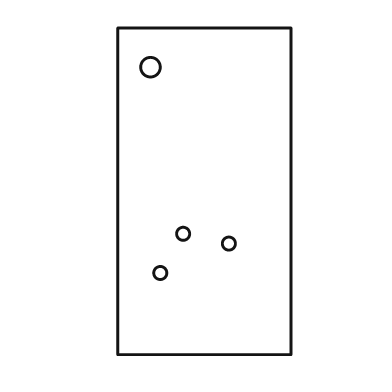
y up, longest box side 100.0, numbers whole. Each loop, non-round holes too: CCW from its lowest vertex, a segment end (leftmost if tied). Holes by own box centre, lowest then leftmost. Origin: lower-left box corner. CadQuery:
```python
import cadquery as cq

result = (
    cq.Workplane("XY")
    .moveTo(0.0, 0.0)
    .lineTo(53.0, 0.0)
    .lineTo(53.0, 100.0)
    .lineTo(0.0, 100.0)
    .close()
    .moveTo(13.0, 25.0)
    .circle(2.0)
    .moveTo(34.0, 34.0)
    .circle(2.0)
    .moveTo(20.0, 37.0)
    .circle(2.0)
    .moveTo(10.0, 88.0)
    .circle(3.0)
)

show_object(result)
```